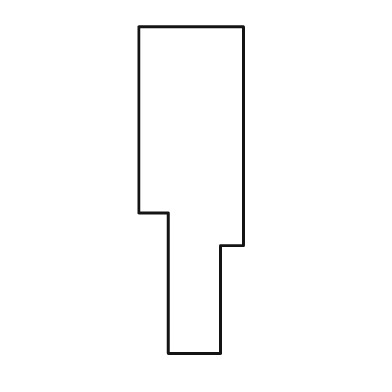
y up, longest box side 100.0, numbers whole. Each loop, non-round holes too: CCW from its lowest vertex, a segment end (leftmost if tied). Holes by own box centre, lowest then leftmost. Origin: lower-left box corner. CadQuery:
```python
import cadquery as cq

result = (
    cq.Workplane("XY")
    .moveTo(9.0, 0.0)
    .lineTo(25.0, 0.0)
    .lineTo(25.0, 33.0)
    .lineTo(32.0, 33.0)
    .lineTo(32.0, 100.0)
    .lineTo(0.0, 100.0)
    .lineTo(0.0, 43.0)
    .lineTo(9.0, 43.0)
    .close()
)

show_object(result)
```